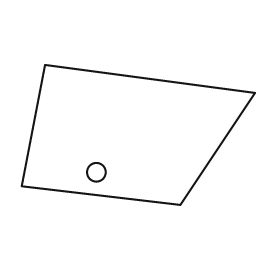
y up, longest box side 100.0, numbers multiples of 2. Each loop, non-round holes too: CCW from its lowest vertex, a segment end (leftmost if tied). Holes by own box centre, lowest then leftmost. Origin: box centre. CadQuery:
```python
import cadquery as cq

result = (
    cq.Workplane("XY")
    .moveTo(18.0, -30.0)
    .lineTo(50.0, 18.0)
    .lineTo(-40.0, 30.0)
    .lineTo(-50.0, -22.0)
    .close()
    .moveTo(-18.0, -16.0)
    .circle(4.0)
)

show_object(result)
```